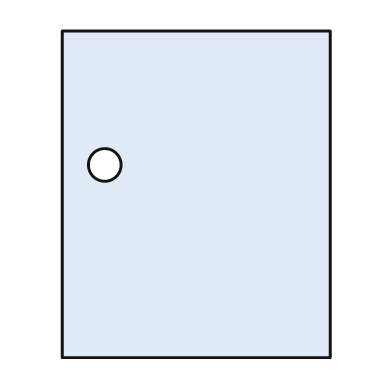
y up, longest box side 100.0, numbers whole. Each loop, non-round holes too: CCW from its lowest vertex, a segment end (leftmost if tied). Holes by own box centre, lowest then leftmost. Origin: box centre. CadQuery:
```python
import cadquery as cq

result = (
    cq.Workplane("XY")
    .moveTo(-41.0, -50.0)
    .lineTo(41.0, -50.0)
    .lineTo(41.0, 50.0)
    .lineTo(-41.0, 50.0)
    .close()
    .moveTo(-28.0, 9.0)
    .circle(5.0)
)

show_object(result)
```